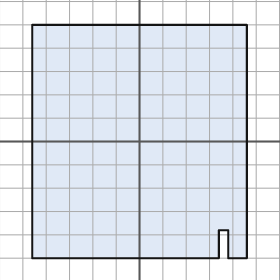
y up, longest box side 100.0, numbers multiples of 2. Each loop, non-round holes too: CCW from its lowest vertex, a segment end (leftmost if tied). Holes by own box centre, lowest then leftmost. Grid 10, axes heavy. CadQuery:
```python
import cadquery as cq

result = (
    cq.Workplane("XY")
    .moveTo(-46.0, -50.0)
    .lineTo(34.0, -50.0)
    .lineTo(34.0, -38.0)
    .lineTo(38.0, -38.0)
    .lineTo(38.0, -50.0)
    .lineTo(46.0, -50.0)
    .lineTo(46.0, 50.0)
    .lineTo(-46.0, 50.0)
    .close()
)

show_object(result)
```